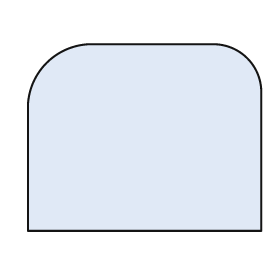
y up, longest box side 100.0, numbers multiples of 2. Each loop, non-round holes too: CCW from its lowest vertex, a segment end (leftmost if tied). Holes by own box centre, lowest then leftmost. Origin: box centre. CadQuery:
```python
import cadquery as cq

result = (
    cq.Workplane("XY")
    .moveTo(-50.0, -40.0)
    .lineTo(50.0, -40.0)
    .lineTo(50.0, 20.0)
    .threePointArc((44.0, 34.0), (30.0, 40.0))
    .lineTo(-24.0, 40.0)
    .threePointArc((-42.0, 32.0), (-50.0, 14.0))
    .close()
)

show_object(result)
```